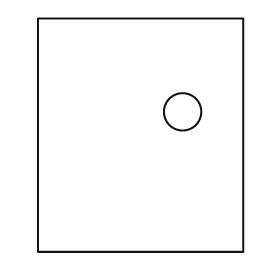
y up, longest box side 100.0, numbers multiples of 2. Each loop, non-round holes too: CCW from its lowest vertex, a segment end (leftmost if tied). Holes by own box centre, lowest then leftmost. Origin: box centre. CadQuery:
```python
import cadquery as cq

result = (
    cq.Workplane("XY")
    .moveTo(-44.0, -50.0)
    .lineTo(44.0, -50.0)
    .lineTo(44.0, 50.0)
    .lineTo(-44.0, 50.0)
    .close()
    .moveTo(18.0, 10.0)
    .circle(8.0)
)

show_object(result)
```